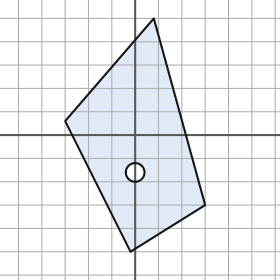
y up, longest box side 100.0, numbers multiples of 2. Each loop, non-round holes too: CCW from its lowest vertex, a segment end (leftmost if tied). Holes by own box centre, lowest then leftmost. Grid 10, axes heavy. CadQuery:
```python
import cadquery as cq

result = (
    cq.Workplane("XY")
    .moveTo(-2.0, -50.0)
    .lineTo(30.0, -30.0)
    .lineTo(8.0, 50.0)
    .lineTo(-30.0, 6.0)
    .close()
    .moveTo(0.0, -16.0)
    .circle(4.0)
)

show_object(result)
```